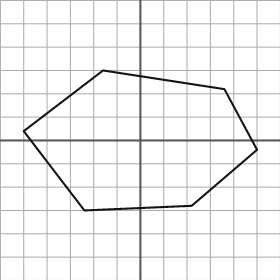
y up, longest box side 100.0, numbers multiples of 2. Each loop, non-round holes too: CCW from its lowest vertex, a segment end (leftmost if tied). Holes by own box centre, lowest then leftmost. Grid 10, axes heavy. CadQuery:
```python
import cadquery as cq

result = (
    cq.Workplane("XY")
    .moveTo(-24.0, -30.0)
    .lineTo(22.0, -28.0)
    .lineTo(50.0, -4.0)
    .lineTo(36.0, 22.0)
    .lineTo(-16.0, 30.0)
    .lineTo(-50.0, 4.0)
    .close()
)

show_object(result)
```